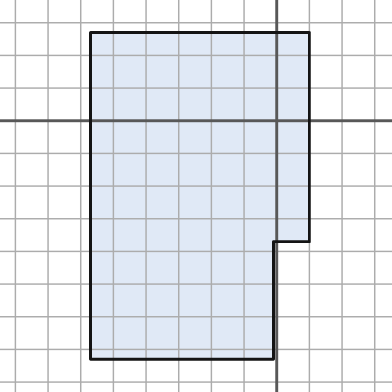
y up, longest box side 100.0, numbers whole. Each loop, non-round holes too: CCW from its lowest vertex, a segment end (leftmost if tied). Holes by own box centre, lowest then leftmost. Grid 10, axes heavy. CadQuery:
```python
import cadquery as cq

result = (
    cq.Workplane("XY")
    .moveTo(-57.0, -73.0)
    .lineTo(-1.0, -73.0)
    .lineTo(-1.0, -37.0)
    .lineTo(10.0, -37.0)
    .lineTo(10.0, 27.0)
    .lineTo(-57.0, 27.0)
    .close()
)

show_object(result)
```